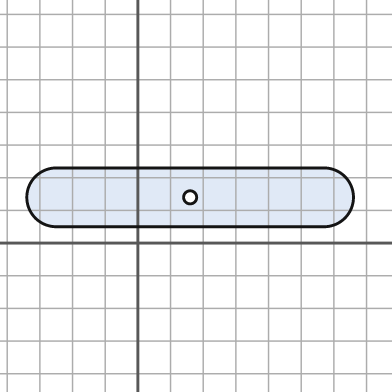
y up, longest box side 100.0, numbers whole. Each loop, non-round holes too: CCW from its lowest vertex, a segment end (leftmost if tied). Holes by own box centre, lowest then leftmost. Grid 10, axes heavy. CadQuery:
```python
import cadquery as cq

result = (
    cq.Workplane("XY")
    .moveTo(-25.0, 5.0)
    .lineTo(57.0, 5.0)
    .threePointArc((66.0, 14.0), (57.0, 23.0))
    .lineTo(-25.0, 23.0)
    .threePointArc((-34.0, 14.0), (-25.0, 5.0))
    .close()
    .moveTo(16.0, 14.0)
    .circle(2.0)
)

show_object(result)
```